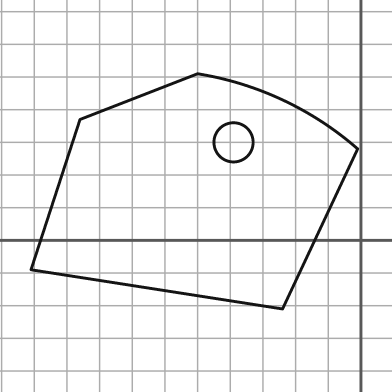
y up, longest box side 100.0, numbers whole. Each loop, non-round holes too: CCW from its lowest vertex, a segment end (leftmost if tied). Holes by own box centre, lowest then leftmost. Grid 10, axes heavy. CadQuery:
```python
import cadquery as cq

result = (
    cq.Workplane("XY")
    .moveTo(-24.0, -21.0)
    .lineTo(-1.0, 28.0)
    .threePointArc((-24.0, 43.0), (-50.0, 51.0))
    .lineTo(-86.0, 37.0)
    .lineTo(-101.0, -9.0)
    .close()
    .moveTo(-39.0, 30.0)
    .circle(6.0)
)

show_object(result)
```